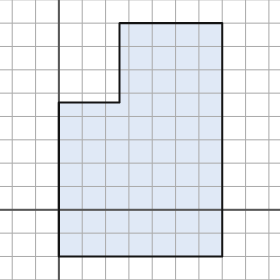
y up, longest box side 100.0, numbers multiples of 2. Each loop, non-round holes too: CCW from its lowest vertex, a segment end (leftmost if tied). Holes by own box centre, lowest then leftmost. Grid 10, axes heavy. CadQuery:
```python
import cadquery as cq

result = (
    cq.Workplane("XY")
    .moveTo(0.0, -20.0)
    .lineTo(70.0, -20.0)
    .lineTo(70.0, 80.0)
    .lineTo(26.0, 80.0)
    .lineTo(26.0, 46.0)
    .lineTo(0.0, 46.0)
    .close()
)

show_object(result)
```